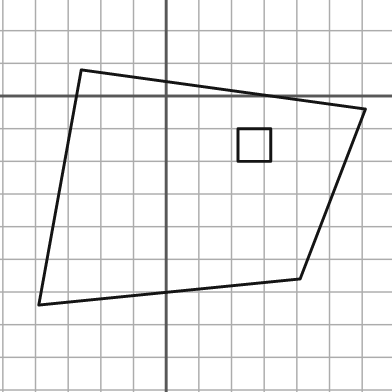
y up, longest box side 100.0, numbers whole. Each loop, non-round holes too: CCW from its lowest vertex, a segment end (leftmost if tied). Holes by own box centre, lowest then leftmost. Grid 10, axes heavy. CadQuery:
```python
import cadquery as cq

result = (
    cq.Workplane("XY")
    .moveTo(-39.0, -64.0)
    .lineTo(41.0, -56.0)
    .lineTo(61.0, -4.0)
    .lineTo(-26.0, 8.0)
    .close()
    .moveTo(22.0, -20.0)
    .lineTo(32.0, -20.0)
    .lineTo(32.0, -10.0)
    .lineTo(22.0, -10.0)
    .close()
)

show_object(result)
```